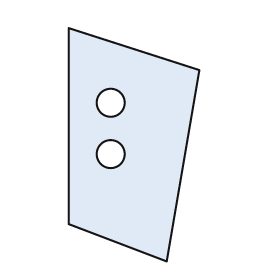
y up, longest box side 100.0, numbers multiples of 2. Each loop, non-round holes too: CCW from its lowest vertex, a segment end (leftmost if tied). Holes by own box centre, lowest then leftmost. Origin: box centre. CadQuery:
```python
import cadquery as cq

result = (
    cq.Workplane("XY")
    .moveTo(14.0, -50.0)
    .lineTo(28.0, 32.0)
    .lineTo(-28.0, 50.0)
    .lineTo(-28.0, -34.0)
    .close()
    .moveTo(-10.0, -4.0)
    .circle(6.0)
    .moveTo(-10.0, 18.0)
    .circle(6.0)
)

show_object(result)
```